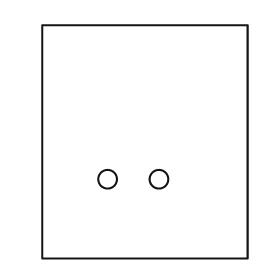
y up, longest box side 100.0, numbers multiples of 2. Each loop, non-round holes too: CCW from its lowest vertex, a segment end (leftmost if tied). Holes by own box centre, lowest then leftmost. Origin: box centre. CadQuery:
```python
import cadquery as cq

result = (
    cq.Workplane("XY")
    .moveTo(-44.0, -50.0)
    .lineTo(44.0, -50.0)
    .lineTo(44.0, 50.0)
    .lineTo(-44.0, 50.0)
    .close()
    .moveTo(-16.0, -16.0)
    .circle(4.0)
    .moveTo(6.0, -16.0)
    .circle(4.0)
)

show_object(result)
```